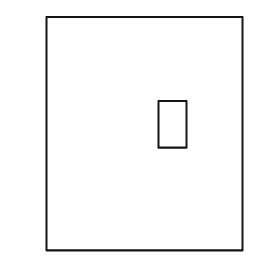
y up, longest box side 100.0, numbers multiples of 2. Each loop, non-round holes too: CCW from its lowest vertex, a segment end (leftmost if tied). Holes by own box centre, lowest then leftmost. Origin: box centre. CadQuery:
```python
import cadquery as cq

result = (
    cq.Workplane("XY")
    .moveTo(-42.0, -50.0)
    .lineTo(42.0, -50.0)
    .lineTo(42.0, 50.0)
    .lineTo(-42.0, 50.0)
    .close()
    .moveTo(6.0, -6.0)
    .lineTo(18.0, -6.0)
    .lineTo(18.0, 14.0)
    .lineTo(6.0, 14.0)
    .close()
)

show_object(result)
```